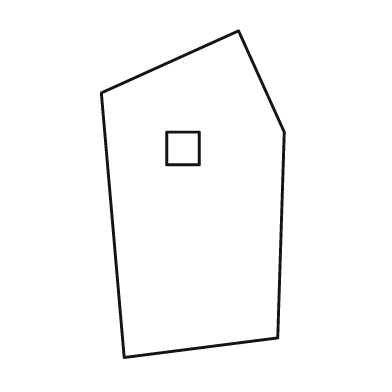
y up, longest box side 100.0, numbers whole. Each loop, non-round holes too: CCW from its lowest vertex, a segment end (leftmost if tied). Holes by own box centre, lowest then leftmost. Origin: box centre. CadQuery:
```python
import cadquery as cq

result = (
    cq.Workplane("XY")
    .moveTo(-21.0, -50.0)
    .lineTo(26.0, -44.0)
    .lineTo(28.0, 19.0)
    .lineTo(14.0, 50.0)
    .lineTo(-28.0, 31.0)
    .close()
    .moveTo(-8.0, 9.0)
    .lineTo(2.0, 9.0)
    .lineTo(2.0, 19.0)
    .lineTo(-8.0, 19.0)
    .close()
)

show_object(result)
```